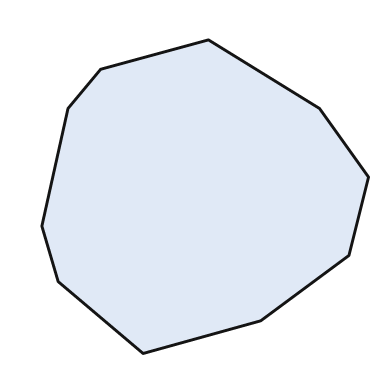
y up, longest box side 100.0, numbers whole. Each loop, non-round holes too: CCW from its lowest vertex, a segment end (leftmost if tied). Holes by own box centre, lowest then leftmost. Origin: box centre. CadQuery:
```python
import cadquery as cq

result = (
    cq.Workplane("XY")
    .moveTo(-19.0, -48.0)
    .lineTo(17.0, -38.0)
    .lineTo(44.0, -18.0)
    .lineTo(50.0, 6.0)
    .lineTo(35.0, 27.0)
    .lineTo(1.0, 48.0)
    .lineTo(-32.0, 39.0)
    .lineTo(-42.0, 27.0)
    .lineTo(-50.0, -9.0)
    .lineTo(-45.0, -26.0)
    .close()
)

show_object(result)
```